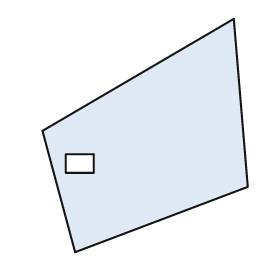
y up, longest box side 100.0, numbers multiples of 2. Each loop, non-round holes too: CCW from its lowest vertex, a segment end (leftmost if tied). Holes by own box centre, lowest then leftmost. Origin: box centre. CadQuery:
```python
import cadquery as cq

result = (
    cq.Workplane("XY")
    .moveTo(-30.0, -50.0)
    .lineTo(44.0, -22.0)
    .lineTo(38.0, 50.0)
    .lineTo(-44.0, 2.0)
    .close()
    .moveTo(-34.0, -16.0)
    .lineTo(-22.0, -16.0)
    .lineTo(-22.0, -8.0)
    .lineTo(-34.0, -8.0)
    .close()
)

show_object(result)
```